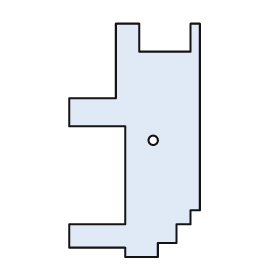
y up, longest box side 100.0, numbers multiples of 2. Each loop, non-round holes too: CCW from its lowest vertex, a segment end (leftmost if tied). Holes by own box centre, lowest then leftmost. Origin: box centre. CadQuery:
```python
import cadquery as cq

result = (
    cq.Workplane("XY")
    .moveTo(-4.0, -50.0)
    .lineTo(10.0, -50.0)
    .lineTo(10.0, -44.0)
    .lineTo(18.0, -44.0)
    .lineTo(18.0, -36.0)
    .lineTo(24.0, -36.0)
    .lineTo(24.0, -30.0)
    .lineTo(28.0, -30.0)
    .lineTo(28.0, 50.0)
    .lineTo(24.0, 50.0)
    .lineTo(24.0, 38.0)
    .lineTo(2.0, 38.0)
    .lineTo(2.0, 50.0)
    .lineTo(-8.0, 50.0)
    .lineTo(-8.0, 18.0)
    .lineTo(-28.0, 18.0)
    .lineTo(-28.0, 6.0)
    .lineTo(-4.0, 6.0)
    .lineTo(-4.0, -36.0)
    .lineTo(-28.0, -36.0)
    .lineTo(-28.0, -46.0)
    .lineTo(-4.0, -46.0)
    .close()
    .moveTo(8.0, 0.0)
    .circle(2.0)
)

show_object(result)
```